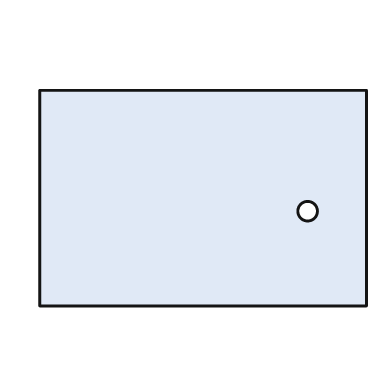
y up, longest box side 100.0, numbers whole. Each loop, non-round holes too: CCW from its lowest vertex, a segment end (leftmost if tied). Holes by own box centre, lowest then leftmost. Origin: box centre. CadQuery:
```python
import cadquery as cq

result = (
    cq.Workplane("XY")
    .moveTo(-50.0, -33.0)
    .lineTo(50.0, -33.0)
    .lineTo(50.0, 33.0)
    .lineTo(-50.0, 33.0)
    .close()
    .moveTo(32.0, -4.0)
    .circle(3.0)
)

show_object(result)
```